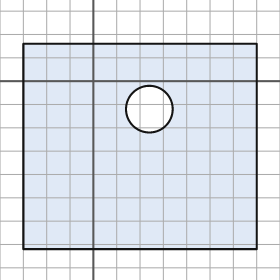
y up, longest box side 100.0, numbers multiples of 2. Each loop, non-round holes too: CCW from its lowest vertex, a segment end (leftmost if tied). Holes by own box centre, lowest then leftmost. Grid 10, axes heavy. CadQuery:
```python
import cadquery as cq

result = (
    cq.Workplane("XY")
    .moveTo(-30.0, -72.0)
    .lineTo(70.0, -72.0)
    .lineTo(70.0, 16.0)
    .lineTo(-30.0, 16.0)
    .close()
    .moveTo(24.0, -12.0)
    .circle(10.0)
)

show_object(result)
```